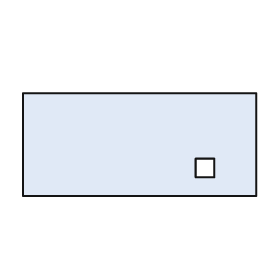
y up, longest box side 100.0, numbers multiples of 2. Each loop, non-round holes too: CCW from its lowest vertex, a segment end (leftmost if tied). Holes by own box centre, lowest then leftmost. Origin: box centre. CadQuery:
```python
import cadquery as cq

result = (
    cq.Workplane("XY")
    .moveTo(-50.0, -22.0)
    .lineTo(50.0, -22.0)
    .lineTo(50.0, 22.0)
    .lineTo(-50.0, 22.0)
    .close()
    .moveTo(24.0, -14.0)
    .lineTo(32.0, -14.0)
    .lineTo(32.0, -6.0)
    .lineTo(24.0, -6.0)
    .close()
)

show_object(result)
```